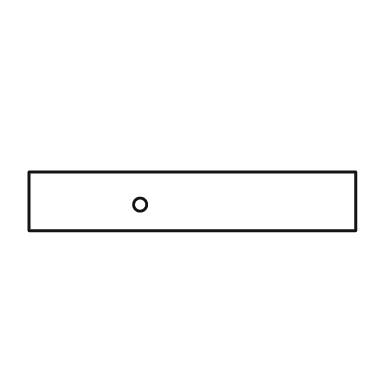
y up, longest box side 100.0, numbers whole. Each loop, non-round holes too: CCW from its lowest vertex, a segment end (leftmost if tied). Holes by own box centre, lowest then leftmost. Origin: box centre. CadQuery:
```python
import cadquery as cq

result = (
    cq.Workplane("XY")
    .moveTo(-50.0, -9.0)
    .lineTo(50.0, -9.0)
    .lineTo(50.0, 9.0)
    .lineTo(-50.0, 9.0)
    .close()
    .moveTo(-16.0, -1.0)
    .circle(2.0)
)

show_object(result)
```